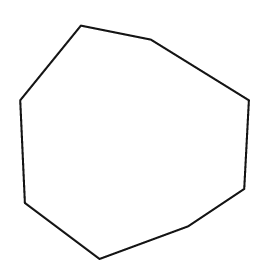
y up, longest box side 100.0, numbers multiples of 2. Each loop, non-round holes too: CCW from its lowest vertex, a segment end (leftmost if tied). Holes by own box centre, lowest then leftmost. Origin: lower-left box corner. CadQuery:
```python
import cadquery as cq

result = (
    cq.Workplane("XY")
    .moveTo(34.0, 0.0)
    .lineTo(72.0, 14.0)
    .lineTo(96.0, 30.0)
    .lineTo(98.0, 68.0)
    .lineTo(56.0, 94.0)
    .lineTo(26.0, 100.0)
    .lineTo(0.0, 68.0)
    .lineTo(2.0, 24.0)
    .close()
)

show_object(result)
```